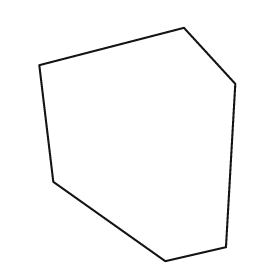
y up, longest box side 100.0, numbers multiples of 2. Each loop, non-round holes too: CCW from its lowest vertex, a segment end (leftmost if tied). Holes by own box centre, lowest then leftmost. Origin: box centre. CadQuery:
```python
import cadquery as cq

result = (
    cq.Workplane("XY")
    .moveTo(12.0, -50.0)
    .lineTo(38.0, -44.0)
    .lineTo(42.0, 26.0)
    .lineTo(20.0, 50.0)
    .lineTo(-42.0, 34.0)
    .lineTo(-36.0, -16.0)
    .close()
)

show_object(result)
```